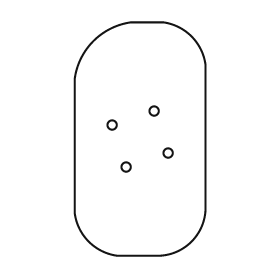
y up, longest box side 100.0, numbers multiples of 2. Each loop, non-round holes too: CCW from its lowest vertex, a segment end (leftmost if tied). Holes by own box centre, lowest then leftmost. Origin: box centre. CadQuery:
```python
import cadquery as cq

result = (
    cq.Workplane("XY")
    .moveTo(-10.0, -50.0)
    .lineTo(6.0, -50.0)
    .threePointArc((22.0, -44.0), (28.0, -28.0))
    .lineTo(28.0, 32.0)
    .threePointArc((22.0, 44.0), (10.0, 50.0))
    .lineTo(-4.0, 50.0)
    .threePointArc((-20.0, 42.0), (-28.0, 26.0))
    .lineTo(-28.0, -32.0)
    .threePointArc((-22.0, -44.0), (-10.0, -50.0))
    .close()
    .moveTo(-6.0, -12.0)
    .circle(2.0)
    .moveTo(12.0, -6.0)
    .circle(2.0)
    .moveTo(-12.0, 6.0)
    .circle(2.0)
    .moveTo(6.0, 12.0)
    .circle(2.0)
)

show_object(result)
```